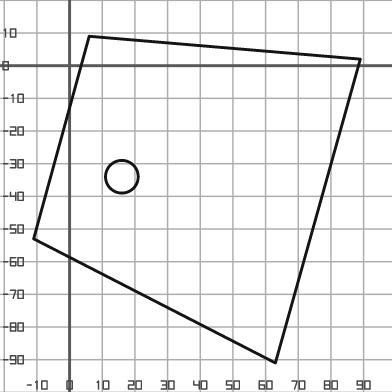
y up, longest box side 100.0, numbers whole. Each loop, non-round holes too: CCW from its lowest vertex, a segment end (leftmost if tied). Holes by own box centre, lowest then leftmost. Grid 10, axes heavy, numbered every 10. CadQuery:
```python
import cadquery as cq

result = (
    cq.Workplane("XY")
    .moveTo(63.0, -91.0)
    .lineTo(89.0, 2.0)
    .lineTo(6.0, 9.0)
    .lineTo(-11.0, -53.0)
    .close()
    .moveTo(16.0, -34.0)
    .circle(5.0)
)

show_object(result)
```